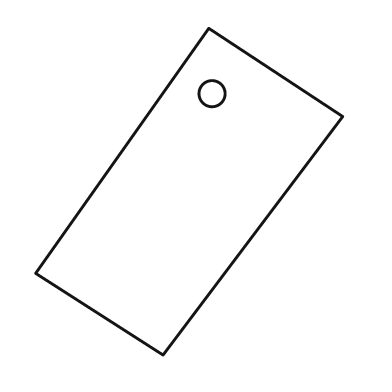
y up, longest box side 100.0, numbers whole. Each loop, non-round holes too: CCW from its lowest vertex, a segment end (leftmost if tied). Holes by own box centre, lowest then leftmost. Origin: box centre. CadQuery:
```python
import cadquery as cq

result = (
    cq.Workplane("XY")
    .moveTo(-8.0, -50.0)
    .lineTo(47.0, 23.0)
    .lineTo(6.0, 50.0)
    .lineTo(-47.0, -25.0)
    .close()
    .moveTo(7.0, 30.0)
    .circle(4.0)
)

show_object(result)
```